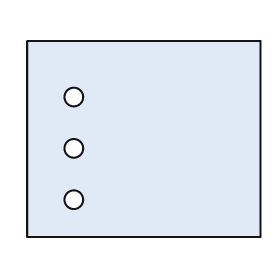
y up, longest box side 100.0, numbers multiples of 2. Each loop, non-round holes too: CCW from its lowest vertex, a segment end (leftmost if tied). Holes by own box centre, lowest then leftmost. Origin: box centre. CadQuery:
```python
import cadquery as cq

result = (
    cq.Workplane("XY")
    .moveTo(-50.0, -42.0)
    .lineTo(50.0, -42.0)
    .lineTo(50.0, 42.0)
    .lineTo(-50.0, 42.0)
    .close()
    .moveTo(-30.0, -26.0)
    .circle(4.0)
    .moveTo(-30.0, -4.0)
    .circle(4.0)
    .moveTo(-30.0, 18.0)
    .circle(4.0)
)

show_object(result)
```